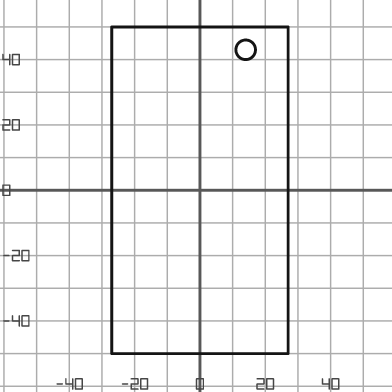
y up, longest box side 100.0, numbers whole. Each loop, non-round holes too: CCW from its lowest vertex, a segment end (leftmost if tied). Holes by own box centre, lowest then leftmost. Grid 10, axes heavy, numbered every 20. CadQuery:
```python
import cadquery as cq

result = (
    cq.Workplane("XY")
    .moveTo(-27.0, -50.0)
    .lineTo(27.0, -50.0)
    .lineTo(27.0, 50.0)
    .lineTo(-27.0, 50.0)
    .close()
    .moveTo(14.0, 43.0)
    .circle(3.0)
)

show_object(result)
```